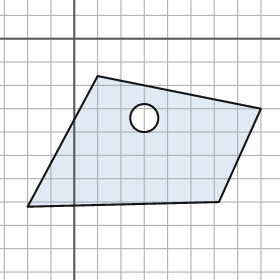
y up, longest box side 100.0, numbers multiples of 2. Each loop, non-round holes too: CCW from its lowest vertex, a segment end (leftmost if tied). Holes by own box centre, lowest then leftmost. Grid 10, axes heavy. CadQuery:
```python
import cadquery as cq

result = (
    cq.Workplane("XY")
    .moveTo(-20.0, -72.0)
    .lineTo(62.0, -70.0)
    .lineTo(80.0, -30.0)
    .lineTo(10.0, -16.0)
    .close()
    .moveTo(30.0, -34.0)
    .circle(6.0)
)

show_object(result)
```